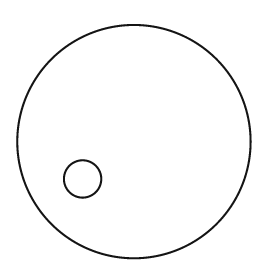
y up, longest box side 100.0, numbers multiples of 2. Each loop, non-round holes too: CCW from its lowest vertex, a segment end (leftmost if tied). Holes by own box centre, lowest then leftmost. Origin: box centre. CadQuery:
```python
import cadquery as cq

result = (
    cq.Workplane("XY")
    .moveTo(0.0, 0.0)
    .circle(50.0)
    .moveTo(-22.0, -16.0)
    .circle(8.0)
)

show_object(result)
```